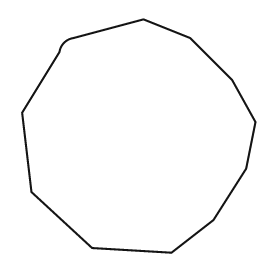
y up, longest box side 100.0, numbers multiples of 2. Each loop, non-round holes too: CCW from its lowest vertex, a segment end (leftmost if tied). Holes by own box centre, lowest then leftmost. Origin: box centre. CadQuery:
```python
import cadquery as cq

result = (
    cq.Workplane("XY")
    .moveTo(14.0, -50.0)
    .lineTo(32.0, -36.0)
    .lineTo(46.0, -14.0)
    .lineTo(50.0, 6.0)
    .lineTo(40.0, 24.0)
    .lineTo(22.0, 42.0)
    .lineTo(2.0, 50.0)
    .lineTo(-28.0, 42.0)
    .threePointArc((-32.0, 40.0), (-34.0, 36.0))
    .lineTo(-50.0, 10.0)
    .lineTo(-46.0, -24.0)
    .lineTo(-20.0, -48.0)
    .close()
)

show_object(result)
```